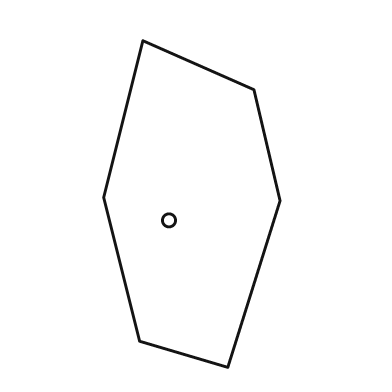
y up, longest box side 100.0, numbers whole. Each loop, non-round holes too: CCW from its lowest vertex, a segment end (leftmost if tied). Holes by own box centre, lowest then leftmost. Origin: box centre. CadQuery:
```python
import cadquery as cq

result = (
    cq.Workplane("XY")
    .moveTo(11.0, -50.0)
    .lineTo(27.0, 1.0)
    .lineTo(19.0, 35.0)
    .lineTo(-15.0, 50.0)
    .lineTo(-27.0, 2.0)
    .lineTo(-16.0, -42.0)
    .close()
    .moveTo(-7.0, -5.0)
    .circle(2.0)
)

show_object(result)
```